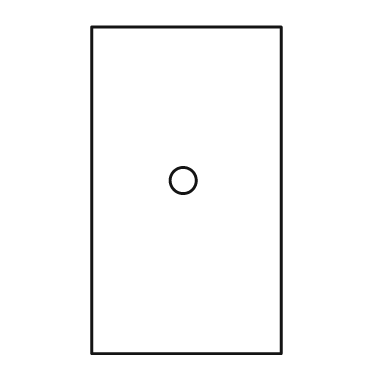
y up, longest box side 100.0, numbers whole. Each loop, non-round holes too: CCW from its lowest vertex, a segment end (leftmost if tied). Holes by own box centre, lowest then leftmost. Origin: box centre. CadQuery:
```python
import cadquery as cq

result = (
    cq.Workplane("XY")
    .moveTo(-29.0, -50.0)
    .lineTo(29.0, -50.0)
    .lineTo(29.0, 50.0)
    .lineTo(-29.0, 50.0)
    .close()
    .moveTo(-1.0, 3.0)
    .circle(4.0)
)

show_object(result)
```